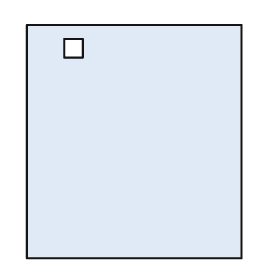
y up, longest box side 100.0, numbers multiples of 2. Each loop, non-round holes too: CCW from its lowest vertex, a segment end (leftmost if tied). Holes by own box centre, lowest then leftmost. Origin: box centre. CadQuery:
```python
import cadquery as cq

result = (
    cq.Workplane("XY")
    .moveTo(-46.0, -50.0)
    .lineTo(46.0, -50.0)
    .lineTo(46.0, 50.0)
    .lineTo(-46.0, 50.0)
    .close()
    .moveTo(-30.0, 36.0)
    .lineTo(-22.0, 36.0)
    .lineTo(-22.0, 44.0)
    .lineTo(-30.0, 44.0)
    .close()
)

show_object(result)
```